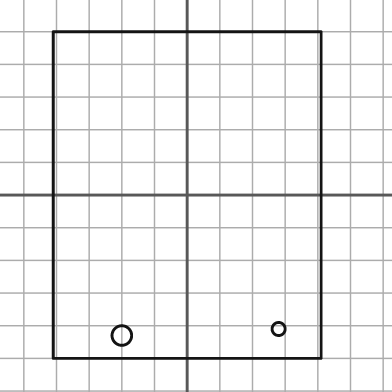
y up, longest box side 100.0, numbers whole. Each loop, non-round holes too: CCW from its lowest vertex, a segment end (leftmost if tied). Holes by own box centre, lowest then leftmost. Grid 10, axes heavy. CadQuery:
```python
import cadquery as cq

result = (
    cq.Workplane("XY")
    .moveTo(-41.0, -50.0)
    .lineTo(41.0, -50.0)
    .lineTo(41.0, 50.0)
    .lineTo(-41.0, 50.0)
    .close()
    .moveTo(-20.0, -43.0)
    .circle(3.0)
    .moveTo(28.0, -41.0)
    .circle(2.0)
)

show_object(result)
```